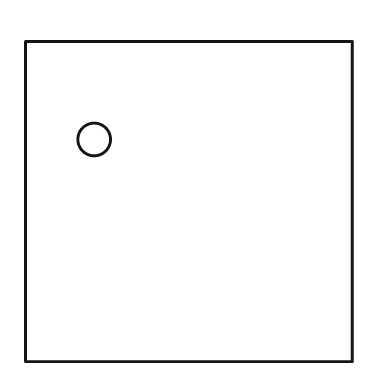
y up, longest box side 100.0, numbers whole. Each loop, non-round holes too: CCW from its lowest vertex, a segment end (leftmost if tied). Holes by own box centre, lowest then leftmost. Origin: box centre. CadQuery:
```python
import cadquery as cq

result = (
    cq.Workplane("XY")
    .moveTo(-50.0, -49.0)
    .lineTo(50.0, -49.0)
    .lineTo(50.0, 49.0)
    .lineTo(-50.0, 49.0)
    .close()
    .moveTo(-29.0, 19.0)
    .circle(5.0)
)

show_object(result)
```